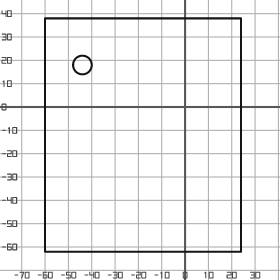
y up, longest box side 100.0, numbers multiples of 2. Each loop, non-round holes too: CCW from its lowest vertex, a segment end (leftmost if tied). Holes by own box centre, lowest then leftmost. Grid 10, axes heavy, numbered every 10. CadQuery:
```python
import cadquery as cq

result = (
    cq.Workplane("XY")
    .moveTo(-60.0, -62.0)
    .lineTo(24.0, -62.0)
    .lineTo(24.0, 38.0)
    .lineTo(-60.0, 38.0)
    .close()
    .moveTo(-44.0, 18.0)
    .circle(4.0)
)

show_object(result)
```